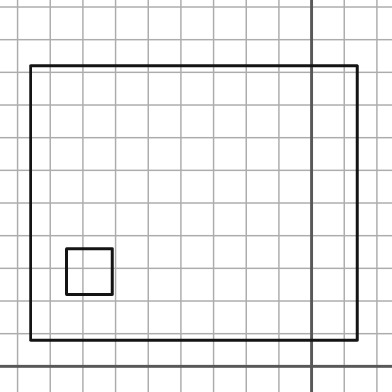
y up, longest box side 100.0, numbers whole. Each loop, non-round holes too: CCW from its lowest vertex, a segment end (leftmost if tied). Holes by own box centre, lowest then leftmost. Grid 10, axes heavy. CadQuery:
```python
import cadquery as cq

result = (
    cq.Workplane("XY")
    .moveTo(-86.0, 8.0)
    .lineTo(14.0, 8.0)
    .lineTo(14.0, 92.0)
    .lineTo(-86.0, 92.0)
    .close()
    .moveTo(-75.0, 22.0)
    .lineTo(-61.0, 22.0)
    .lineTo(-61.0, 36.0)
    .lineTo(-75.0, 36.0)
    .close()
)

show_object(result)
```